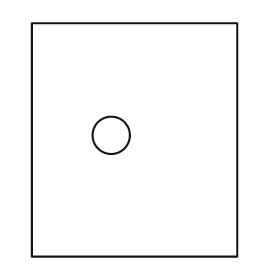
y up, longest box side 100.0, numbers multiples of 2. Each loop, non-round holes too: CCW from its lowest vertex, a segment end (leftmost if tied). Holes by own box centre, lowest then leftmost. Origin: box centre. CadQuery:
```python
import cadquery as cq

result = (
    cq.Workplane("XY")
    .moveTo(-44.0, -50.0)
    .lineTo(44.0, -50.0)
    .lineTo(44.0, 50.0)
    .lineTo(-44.0, 50.0)
    .close()
    .moveTo(-10.0, 2.0)
    .circle(8.0)
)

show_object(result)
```